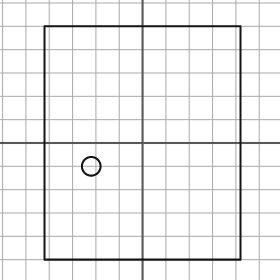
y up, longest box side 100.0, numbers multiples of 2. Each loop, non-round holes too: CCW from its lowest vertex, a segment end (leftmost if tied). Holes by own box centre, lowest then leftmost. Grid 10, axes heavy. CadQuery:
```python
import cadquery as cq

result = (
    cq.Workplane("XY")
    .moveTo(-42.0, -50.0)
    .lineTo(42.0, -50.0)
    .lineTo(42.0, 50.0)
    .lineTo(-42.0, 50.0)
    .close()
    .moveTo(-22.0, -10.0)
    .circle(4.0)
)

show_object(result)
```